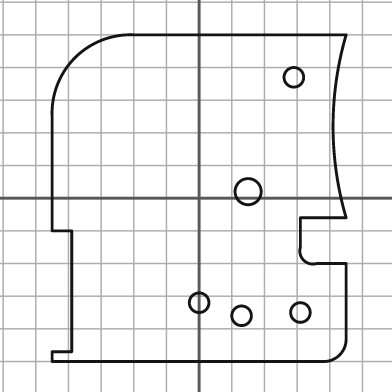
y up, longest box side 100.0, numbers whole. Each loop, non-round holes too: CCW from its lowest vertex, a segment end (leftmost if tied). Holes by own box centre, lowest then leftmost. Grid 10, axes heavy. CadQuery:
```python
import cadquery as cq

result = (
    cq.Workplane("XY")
    .moveTo(-45.0, -50.0)
    .lineTo(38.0, -50.0)
    .threePointArc((43.0, -48.0), (45.0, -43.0))
    .lineTo(45.0, -20.0)
    .lineTo(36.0, -20.0)
    .threePointArc((32.0, -19.0), (31.0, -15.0))
    .lineTo(31.0, -6.0)
    .lineTo(45.0, -6.0)
    .threePointArc((41.0, 22.0), (45.0, 50.0))
    .lineTo(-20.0, 50.0)
    .threePointArc((-38.0, 43.0), (-45.0, 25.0))
    .lineTo(-45.0, -10.0)
    .lineTo(-39.0, -10.0)
    .lineTo(-39.0, -47.0)
    .lineTo(-45.0, -47.0)
    .close()
    .moveTo(13.0, -36.0)
    .circle(3.0)
    .moveTo(31.0, -35.0)
    .circle(3.0)
    .moveTo(0.0, -32.0)
    .circle(3.0)
    .moveTo(15.0, 2.0)
    .circle(4.0)
    .moveTo(29.0, 37.0)
    .circle(3.0)
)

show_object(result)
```